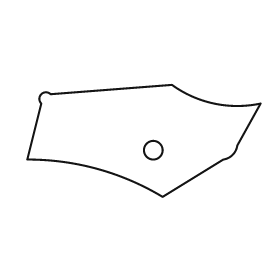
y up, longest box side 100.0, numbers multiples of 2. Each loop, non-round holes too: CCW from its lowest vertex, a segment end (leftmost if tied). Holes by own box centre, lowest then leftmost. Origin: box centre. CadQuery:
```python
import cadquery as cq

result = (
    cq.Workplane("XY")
    .moveTo(8.0, -24.0)
    .lineTo(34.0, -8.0)
    .threePointArc((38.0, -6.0), (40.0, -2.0))
    .lineTo(50.0, 16.0)
    .threePointArc((30.0, 16.0), (12.0, 24.0))
    .lineTo(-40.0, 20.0)
    .threePointArc((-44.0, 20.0), (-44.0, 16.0))
    .lineTo(-50.0, -8.0)
    .threePointArc((-20.0, -12.0), (8.0, -24.0))
    .close()
    .moveTo(4.0, -4.0)
    .circle(4.0)
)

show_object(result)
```